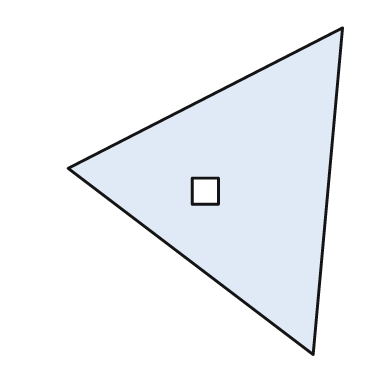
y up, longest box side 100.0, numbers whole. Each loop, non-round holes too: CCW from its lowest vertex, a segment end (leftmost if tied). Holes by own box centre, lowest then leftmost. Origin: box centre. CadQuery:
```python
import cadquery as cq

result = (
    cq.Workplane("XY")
    .moveTo(33.0, -50.0)
    .lineTo(42.0, 50.0)
    .lineTo(-42.0, 7.0)
    .close()
    .moveTo(-4.0, -4.0)
    .lineTo(4.0, -4.0)
    .lineTo(4.0, 4.0)
    .lineTo(-4.0, 4.0)
    .close()
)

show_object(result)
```